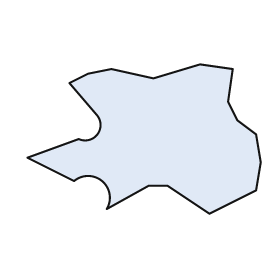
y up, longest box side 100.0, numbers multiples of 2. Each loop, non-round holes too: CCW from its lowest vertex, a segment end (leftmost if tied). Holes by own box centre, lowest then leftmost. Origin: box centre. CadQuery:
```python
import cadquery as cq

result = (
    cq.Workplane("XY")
    .moveTo(28.0, -32.0)
    .lineTo(48.0, -22.0)
    .lineTo(50.0, -10.0)
    .lineTo(48.0, 2.0)
    .lineTo(40.0, 8.0)
    .lineTo(36.0, 16.0)
    .lineTo(38.0, 30.0)
    .lineTo(24.0, 32.0)
    .lineTo(4.0, 26.0)
    .lineTo(-14.0, 30.0)
    .lineTo(-24.0, 28.0)
    .lineTo(-32.0, 24.0)
    .lineTo(-20.0, 10.0)
    .threePointArc((-20.0, 2.0), (-28.0, 0.0))
    .lineTo(-50.0, -8.0)
    .lineTo(-30.0, -18.0)
    .threePointArc((-18.0, -18.0), (-16.0, -30.0))
    .lineTo(2.0, -20.0)
    .lineTo(10.0, -20.0)
    .close()
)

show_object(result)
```